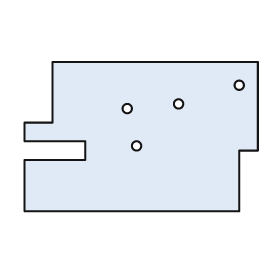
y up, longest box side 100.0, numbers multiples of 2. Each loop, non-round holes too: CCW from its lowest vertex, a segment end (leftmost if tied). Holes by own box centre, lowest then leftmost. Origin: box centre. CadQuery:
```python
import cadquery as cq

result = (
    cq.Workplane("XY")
    .moveTo(-50.0, -32.0)
    .lineTo(42.0, -32.0)
    .lineTo(42.0, -6.0)
    .lineTo(50.0, -6.0)
    .lineTo(50.0, 32.0)
    .lineTo(-38.0, 32.0)
    .lineTo(-38.0, 6.0)
    .lineTo(-50.0, 6.0)
    .lineTo(-50.0, -2.0)
    .lineTo(-24.0, -2.0)
    .lineTo(-24.0, -10.0)
    .lineTo(-50.0, -10.0)
    .close()
    .moveTo(-2.0, -4.0)
    .circle(2.0)
    .moveTo(-6.0, 12.0)
    .circle(2.0)
    .moveTo(16.0, 14.0)
    .circle(2.0)
    .moveTo(42.0, 22.0)
    .circle(2.0)
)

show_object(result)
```